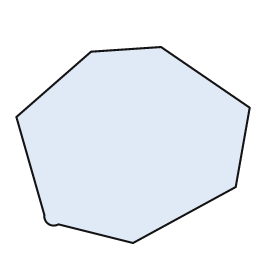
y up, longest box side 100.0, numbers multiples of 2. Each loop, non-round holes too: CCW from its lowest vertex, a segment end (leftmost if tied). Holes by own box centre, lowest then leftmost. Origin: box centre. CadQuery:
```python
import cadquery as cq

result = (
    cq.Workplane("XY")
    .moveTo(0.0, -42.0)
    .lineTo(44.0, -18.0)
    .lineTo(50.0, 16.0)
    .lineTo(12.0, 42.0)
    .lineTo(-18.0, 40.0)
    .lineTo(-50.0, 12.0)
    .lineTo(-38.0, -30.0)
    .threePointArc((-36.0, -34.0), (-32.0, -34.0))
    .close()
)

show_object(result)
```